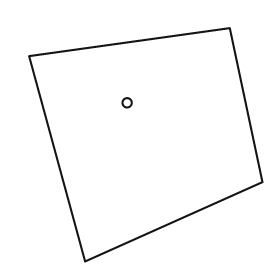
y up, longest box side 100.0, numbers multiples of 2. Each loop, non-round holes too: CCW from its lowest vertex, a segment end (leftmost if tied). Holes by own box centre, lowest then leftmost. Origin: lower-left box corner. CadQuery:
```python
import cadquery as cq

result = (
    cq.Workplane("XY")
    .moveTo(24.0, 0.0)
    .lineTo(100.0, 34.0)
    .lineTo(86.0, 100.0)
    .lineTo(0.0, 88.0)
    .close()
    .moveTo(42.0, 68.0)
    .circle(2.0)
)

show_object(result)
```